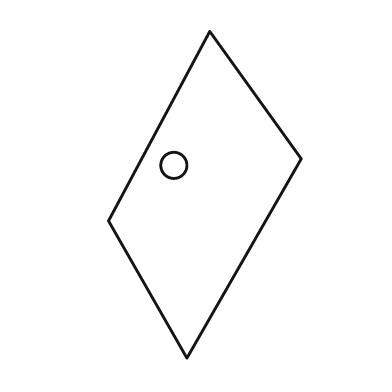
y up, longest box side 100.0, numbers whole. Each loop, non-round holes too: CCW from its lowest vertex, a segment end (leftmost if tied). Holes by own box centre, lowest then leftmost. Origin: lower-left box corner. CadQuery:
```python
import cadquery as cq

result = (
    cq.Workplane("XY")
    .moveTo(24.0, 0.0)
    .lineTo(59.0, 61.0)
    .lineTo(31.0, 100.0)
    .lineTo(0.0, 42.0)
    .close()
    .moveTo(20.0, 59.0)
    .circle(4.0)
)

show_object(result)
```